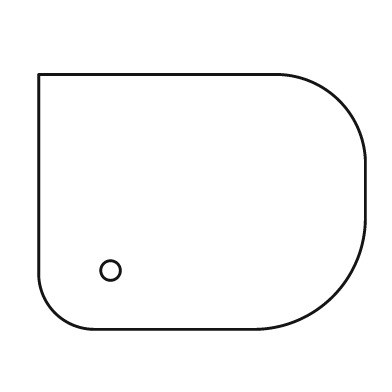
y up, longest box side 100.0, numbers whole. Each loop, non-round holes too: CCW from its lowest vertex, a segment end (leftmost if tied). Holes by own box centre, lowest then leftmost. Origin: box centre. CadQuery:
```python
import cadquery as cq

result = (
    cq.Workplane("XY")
    .moveTo(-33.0, -39.0)
    .lineTo(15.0, -39.0)
    .threePointArc((40.0, -29.0), (50.0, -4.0))
    .lineTo(50.0, 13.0)
    .threePointArc((42.0, 31.0), (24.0, 39.0))
    .lineTo(-50.0, 39.0)
    .lineTo(-50.0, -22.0)
    .threePointArc((-45.0, -34.0), (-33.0, -39.0))
    .close()
    .moveTo(-28.0, -21.0)
    .circle(3.0)
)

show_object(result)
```